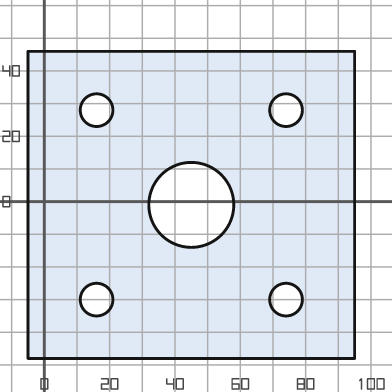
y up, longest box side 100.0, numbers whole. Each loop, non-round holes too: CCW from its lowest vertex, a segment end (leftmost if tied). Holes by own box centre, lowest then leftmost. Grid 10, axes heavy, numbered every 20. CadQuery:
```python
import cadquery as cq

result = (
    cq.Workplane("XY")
    .moveTo(-5.0, -48.0)
    .lineTo(95.0, -48.0)
    .lineTo(95.0, 46.0)
    .lineTo(-5.0, 46.0)
    .close()
    .moveTo(16.0, -30.0)
    .circle(5.0)
    .moveTo(74.0, -30.0)
    .circle(5.0)
    .moveTo(45.0, -1.0)
    .circle(13.0)
    .moveTo(16.0, 28.0)
    .circle(5.0)
    .moveTo(74.0, 28.0)
    .circle(5.0)
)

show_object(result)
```